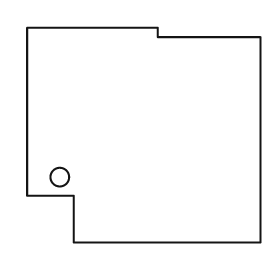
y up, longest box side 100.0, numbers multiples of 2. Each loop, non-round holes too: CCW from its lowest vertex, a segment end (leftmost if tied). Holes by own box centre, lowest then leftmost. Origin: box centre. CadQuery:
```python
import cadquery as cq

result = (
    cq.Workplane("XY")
    .moveTo(-30.0, -46.0)
    .lineTo(50.0, -46.0)
    .lineTo(50.0, 42.0)
    .lineTo(6.0, 42.0)
    .lineTo(6.0, 46.0)
    .lineTo(-50.0, 46.0)
    .lineTo(-50.0, -26.0)
    .lineTo(-30.0, -26.0)
    .close()
    .moveTo(-36.0, -18.0)
    .circle(4.0)
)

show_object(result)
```